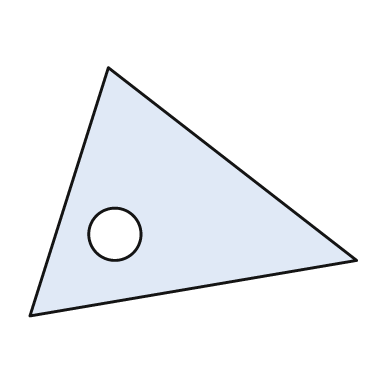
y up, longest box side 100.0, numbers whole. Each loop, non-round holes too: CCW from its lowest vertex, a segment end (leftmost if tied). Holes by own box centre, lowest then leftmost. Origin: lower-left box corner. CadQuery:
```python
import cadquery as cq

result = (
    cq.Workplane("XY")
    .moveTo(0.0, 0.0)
    .lineTo(100.0, 17.0)
    .lineTo(24.0, 76.0)
    .close()
    .moveTo(26.0, 25.0)
    .circle(8.0)
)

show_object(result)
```